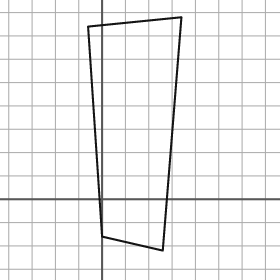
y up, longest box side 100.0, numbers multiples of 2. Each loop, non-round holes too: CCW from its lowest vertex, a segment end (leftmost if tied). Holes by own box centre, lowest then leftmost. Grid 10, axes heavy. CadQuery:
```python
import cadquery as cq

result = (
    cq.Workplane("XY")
    .moveTo(26.0, -22.0)
    .lineTo(34.0, 78.0)
    .lineTo(-6.0, 74.0)
    .lineTo(0.0, -16.0)
    .close()
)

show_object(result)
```